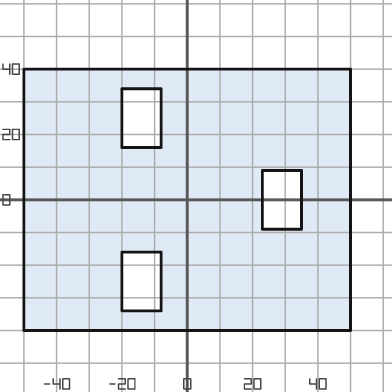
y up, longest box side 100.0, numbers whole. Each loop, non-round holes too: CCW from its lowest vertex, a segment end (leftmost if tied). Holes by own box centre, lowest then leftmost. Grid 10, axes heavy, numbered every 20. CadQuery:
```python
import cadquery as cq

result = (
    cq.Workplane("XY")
    .moveTo(-50.0, -40.0)
    .lineTo(50.0, -40.0)
    .lineTo(50.0, 40.0)
    .lineTo(-50.0, 40.0)
    .close()
    .moveTo(-20.0, -34.0)
    .lineTo(-8.0, -34.0)
    .lineTo(-8.0, -16.0)
    .lineTo(-20.0, -16.0)
    .close()
    .moveTo(23.0, -9.0)
    .lineTo(35.0, -9.0)
    .lineTo(35.0, 9.0)
    .lineTo(23.0, 9.0)
    .close()
    .moveTo(-20.0, 16.0)
    .lineTo(-8.0, 16.0)
    .lineTo(-8.0, 34.0)
    .lineTo(-20.0, 34.0)
    .close()
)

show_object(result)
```